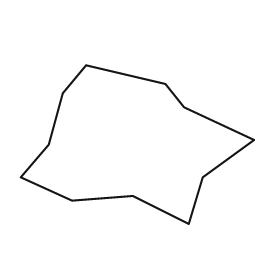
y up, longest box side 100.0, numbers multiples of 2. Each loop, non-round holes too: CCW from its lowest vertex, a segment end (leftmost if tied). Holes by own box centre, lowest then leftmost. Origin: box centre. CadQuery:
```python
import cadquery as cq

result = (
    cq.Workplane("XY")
    .moveTo(22.0, -34.0)
    .lineTo(28.0, -14.0)
    .lineTo(50.0, 2.0)
    .lineTo(20.0, 16.0)
    .lineTo(12.0, 26.0)
    .lineTo(-22.0, 34.0)
    .lineTo(-32.0, 22.0)
    .lineTo(-38.0, 0.0)
    .lineTo(-50.0, -14.0)
    .lineTo(-28.0, -24.0)
    .lineTo(-2.0, -22.0)
    .close()
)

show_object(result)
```